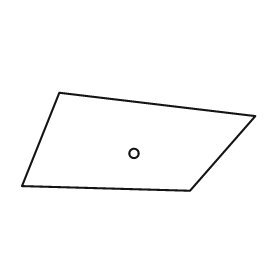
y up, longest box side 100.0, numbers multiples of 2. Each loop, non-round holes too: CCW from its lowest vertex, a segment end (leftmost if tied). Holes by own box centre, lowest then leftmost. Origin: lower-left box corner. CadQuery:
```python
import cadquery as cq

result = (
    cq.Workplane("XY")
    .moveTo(72.0, 0.0)
    .lineTo(100.0, 32.0)
    .lineTo(16.0, 42.0)
    .lineTo(0.0, 2.0)
    .close()
    .moveTo(48.0, 16.0)
    .circle(2.0)
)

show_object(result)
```